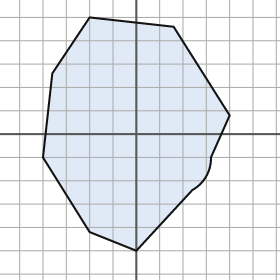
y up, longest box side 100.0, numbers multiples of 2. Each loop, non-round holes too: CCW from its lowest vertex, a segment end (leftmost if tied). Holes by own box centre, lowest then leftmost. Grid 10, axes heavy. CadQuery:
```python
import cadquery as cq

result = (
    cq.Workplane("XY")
    .moveTo(0.0, -50.0)
    .lineTo(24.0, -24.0)
    .threePointArc((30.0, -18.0), (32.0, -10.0))
    .lineTo(40.0, 8.0)
    .lineTo(16.0, 46.0)
    .lineTo(-20.0, 50.0)
    .lineTo(-36.0, 26.0)
    .lineTo(-40.0, -10.0)
    .lineTo(-20.0, -42.0)
    .close()
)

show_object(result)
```